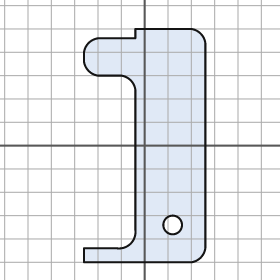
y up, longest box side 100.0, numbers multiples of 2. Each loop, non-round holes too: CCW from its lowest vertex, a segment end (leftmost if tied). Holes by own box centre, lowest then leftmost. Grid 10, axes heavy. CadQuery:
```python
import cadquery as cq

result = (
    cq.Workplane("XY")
    .moveTo(-26.0, -50.0)
    .lineTo(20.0, -50.0)
    .threePointArc((24.0, -48.0), (26.0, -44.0))
    .lineTo(26.0, 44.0)
    .threePointArc((24.0, 48.0), (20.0, 50.0))
    .lineTo(-4.0, 50.0)
    .lineTo(-4.0, 46.0)
    .lineTo(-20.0, 46.0)
    .threePointArc((-24.0, 44.0), (-26.0, 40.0))
    .lineTo(-26.0, 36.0)
    .threePointArc((-24.0, 32.0), (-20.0, 30.0))
    .lineTo(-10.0, 30.0)
    .threePointArc((-6.0, 28.0), (-4.0, 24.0))
    .lineTo(-4.0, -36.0)
    .threePointArc((-6.0, -42.0), (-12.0, -44.0))
    .lineTo(-26.0, -44.0)
    .close()
    .moveTo(12.0, -34.0)
    .circle(4.0)
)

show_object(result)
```